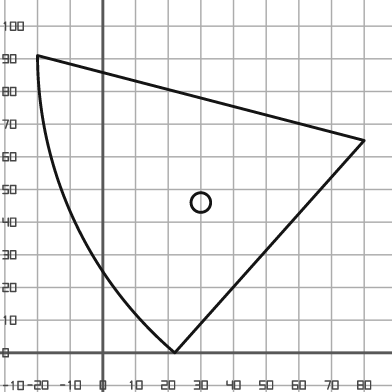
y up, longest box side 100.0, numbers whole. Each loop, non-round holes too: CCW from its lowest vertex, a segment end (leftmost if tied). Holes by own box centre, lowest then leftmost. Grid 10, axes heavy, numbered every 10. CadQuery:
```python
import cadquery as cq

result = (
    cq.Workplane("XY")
    .moveTo(22.0, 0.0)
    .lineTo(80.0, 65.0)
    .lineTo(-20.0, 91.0)
    .threePointArc((-9.0, 41.0), (22.0, 0.0))
    .close()
    .moveTo(30.0, 46.0)
    .circle(3.0)
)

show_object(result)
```